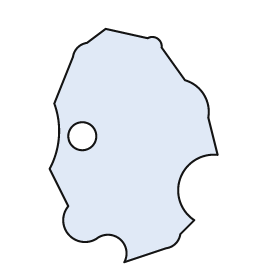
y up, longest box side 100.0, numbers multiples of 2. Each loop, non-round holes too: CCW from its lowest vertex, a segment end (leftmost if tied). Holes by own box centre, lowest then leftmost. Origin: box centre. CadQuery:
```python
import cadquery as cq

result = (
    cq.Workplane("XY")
    .moveTo(-4.0, -50.0)
    .lineTo(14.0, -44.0)
    .threePointArc((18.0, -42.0), (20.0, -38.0))
    .lineTo(26.0, -32.0)
    .threePointArc((20.0, -14.0), (36.0, -4.0))
    .lineTo(32.0, 12.0)
    .threePointArc((30.0, 22.0), (22.0, 28.0))
    .lineTo(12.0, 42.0)
    .threePointArc((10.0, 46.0), (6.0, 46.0))
    .lineTo(-12.0, 50.0)
    .lineTo(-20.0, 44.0)
    .threePointArc((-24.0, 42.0), (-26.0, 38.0))
    .lineTo(-34.0, 18.0)
    .threePointArc((-32.0, 4.0), (-36.0, -10.0))
    .lineTo(-28.0, -26.0)
    .threePointArc((-28.0, -38.0), (-16.0, -40.0))
    .threePointArc((-6.0, -40.0), (-4.0, -50.0))
    .close()
    .moveTo(-22.0, 4.0)
    .circle(6.0)
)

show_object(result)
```